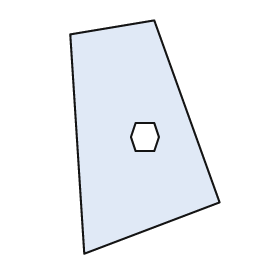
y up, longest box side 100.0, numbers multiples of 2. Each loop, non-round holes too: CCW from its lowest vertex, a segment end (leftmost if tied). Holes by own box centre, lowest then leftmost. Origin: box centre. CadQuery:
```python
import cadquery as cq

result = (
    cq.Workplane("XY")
    .moveTo(-26.0, -50.0)
    .lineTo(32.0, -28.0)
    .lineTo(4.0, 50.0)
    .lineTo(-32.0, 44.0)
    .close()
    .moveTo(-4.0, -6.0)
    .lineTo(4.0, -6.0)
    .lineTo(6.0, 0.0)
    .lineTo(4.0, 6.0)
    .lineTo(-4.0, 6.0)
    .lineTo(-6.0, 0.0)
    .close()
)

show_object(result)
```